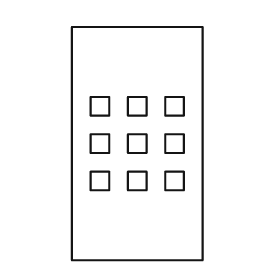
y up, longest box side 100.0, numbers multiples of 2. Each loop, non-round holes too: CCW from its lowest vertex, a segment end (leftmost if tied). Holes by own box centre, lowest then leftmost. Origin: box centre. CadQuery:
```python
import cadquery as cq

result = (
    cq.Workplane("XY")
    .moveTo(-28.0, -50.0)
    .lineTo(28.0, -50.0)
    .lineTo(28.0, 50.0)
    .lineTo(-28.0, 50.0)
    .close()
    .moveTo(-20.0, -20.0)
    .lineTo(-12.0, -20.0)
    .lineTo(-12.0, -12.0)
    .lineTo(-20.0, -12.0)
    .close()
    .moveTo(-4.0, -20.0)
    .lineTo(4.0, -20.0)
    .lineTo(4.0, -12.0)
    .lineTo(-4.0, -12.0)
    .close()
    .moveTo(12.0, -20.0)
    .lineTo(20.0, -20.0)
    .lineTo(20.0, -12.0)
    .lineTo(12.0, -12.0)
    .close()
    .moveTo(-20.0, -4.0)
    .lineTo(-12.0, -4.0)
    .lineTo(-12.0, 4.0)
    .lineTo(-20.0, 4.0)
    .close()
    .moveTo(-4.0, -4.0)
    .lineTo(4.0, -4.0)
    .lineTo(4.0, 4.0)
    .lineTo(-4.0, 4.0)
    .close()
    .moveTo(12.0, -4.0)
    .lineTo(20.0, -4.0)
    .lineTo(20.0, 4.0)
    .lineTo(12.0, 4.0)
    .close()
    .moveTo(-20.0, 12.0)
    .lineTo(-12.0, 12.0)
    .lineTo(-12.0, 20.0)
    .lineTo(-20.0, 20.0)
    .close()
    .moveTo(-4.0, 12.0)
    .lineTo(4.0, 12.0)
    .lineTo(4.0, 20.0)
    .lineTo(-4.0, 20.0)
    .close()
    .moveTo(12.0, 12.0)
    .lineTo(20.0, 12.0)
    .lineTo(20.0, 20.0)
    .lineTo(12.0, 20.0)
    .close()
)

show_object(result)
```